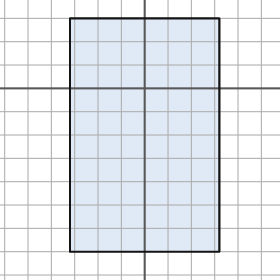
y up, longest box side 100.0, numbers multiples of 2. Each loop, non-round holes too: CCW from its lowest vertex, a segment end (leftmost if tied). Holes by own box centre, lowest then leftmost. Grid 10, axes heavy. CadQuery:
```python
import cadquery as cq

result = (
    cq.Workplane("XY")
    .moveTo(-32.0, -70.0)
    .lineTo(32.0, -70.0)
    .lineTo(32.0, 30.0)
    .lineTo(-32.0, 30.0)
    .close()
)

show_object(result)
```